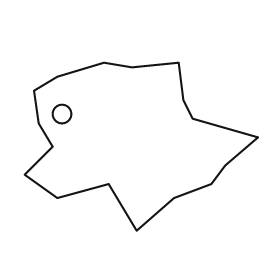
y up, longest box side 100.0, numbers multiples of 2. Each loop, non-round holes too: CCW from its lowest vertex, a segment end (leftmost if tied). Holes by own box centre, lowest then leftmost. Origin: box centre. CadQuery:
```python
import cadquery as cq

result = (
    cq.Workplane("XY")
    .moveTo(-2.0, -36.0)
    .lineTo(14.0, -22.0)
    .lineTo(30.0, -16.0)
    .lineTo(36.0, -8.0)
    .lineTo(50.0, 4.0)
    .lineTo(22.0, 12.0)
    .lineTo(18.0, 20.0)
    .lineTo(16.0, 36.0)
    .lineTo(-4.0, 34.0)
    .lineTo(-16.0, 36.0)
    .lineTo(-36.0, 30.0)
    .lineTo(-46.0, 24.0)
    .lineTo(-44.0, 10.0)
    .lineTo(-38.0, 0.0)
    .lineTo(-50.0, -12.0)
    .lineTo(-36.0, -22.0)
    .lineTo(-14.0, -16.0)
    .close()
    .moveTo(-34.0, 14.0)
    .circle(4.0)
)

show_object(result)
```